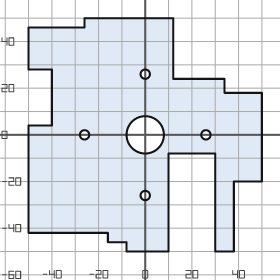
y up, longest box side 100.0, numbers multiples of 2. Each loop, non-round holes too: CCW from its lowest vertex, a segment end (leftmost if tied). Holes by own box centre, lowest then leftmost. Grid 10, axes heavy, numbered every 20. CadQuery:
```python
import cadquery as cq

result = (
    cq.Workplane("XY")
    .moveTo(-8.0, -50.0)
    .lineTo(10.0, -50.0)
    .lineTo(10.0, -8.0)
    .lineTo(30.0, -8.0)
    .lineTo(30.0, -50.0)
    .lineTo(38.0, -50.0)
    .lineTo(38.0, -20.0)
    .lineTo(50.0, -20.0)
    .lineTo(50.0, 18.0)
    .lineTo(34.0, 18.0)
    .lineTo(34.0, 24.0)
    .lineTo(12.0, 24.0)
    .lineTo(12.0, 50.0)
    .lineTo(-26.0, 50.0)
    .lineTo(-26.0, 46.0)
    .lineTo(-50.0, 46.0)
    .lineTo(-50.0, 28.0)
    .lineTo(-40.0, 28.0)
    .lineTo(-40.0, 4.0)
    .lineTo(-50.0, 4.0)
    .lineTo(-50.0, -42.0)
    .lineTo(-16.0, -42.0)
    .lineTo(-16.0, -46.0)
    .lineTo(-8.0, -46.0)
    .close()
    .moveTo(0.0, -26.0)
    .circle(2.0)
    .moveTo(-26.0, 0.0)
    .circle(2.0)
    .moveTo(0.0, 0.0)
    .circle(8.0)
    .moveTo(26.0, 0.0)
    .circle(2.0)
    .moveTo(0.0, 26.0)
    .circle(2.0)
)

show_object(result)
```